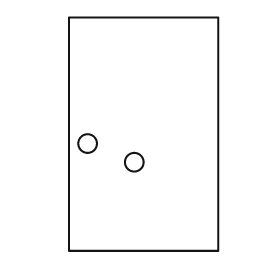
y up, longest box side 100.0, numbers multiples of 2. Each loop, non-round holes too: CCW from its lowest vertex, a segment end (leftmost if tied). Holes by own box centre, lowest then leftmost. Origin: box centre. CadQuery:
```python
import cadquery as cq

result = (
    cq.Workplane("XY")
    .moveTo(-32.0, -50.0)
    .lineTo(32.0, -50.0)
    .lineTo(32.0, 50.0)
    .lineTo(-32.0, 50.0)
    .close()
    .moveTo(-4.0, -12.0)
    .circle(4.0)
    .moveTo(-24.0, -4.0)
    .circle(4.0)
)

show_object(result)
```